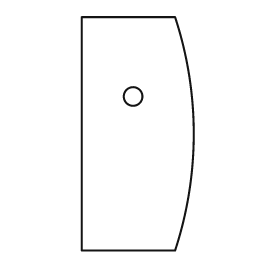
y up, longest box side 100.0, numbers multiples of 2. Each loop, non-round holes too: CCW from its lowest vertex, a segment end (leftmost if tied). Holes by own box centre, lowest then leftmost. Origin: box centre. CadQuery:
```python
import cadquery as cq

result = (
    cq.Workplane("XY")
    .moveTo(-24.0, -50.0)
    .lineTo(16.0, -50.0)
    .threePointArc((24.0, 0.0), (16.0, 50.0))
    .lineTo(-24.0, 50.0)
    .close()
    .moveTo(-2.0, 16.0)
    .circle(4.0)
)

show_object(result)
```